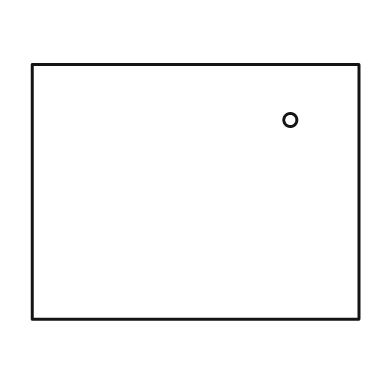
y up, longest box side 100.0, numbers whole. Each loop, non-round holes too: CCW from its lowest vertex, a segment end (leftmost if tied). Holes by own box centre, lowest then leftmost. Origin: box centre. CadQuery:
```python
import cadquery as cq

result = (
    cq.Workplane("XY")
    .moveTo(-50.0, -39.0)
    .lineTo(50.0, -39.0)
    .lineTo(50.0, 39.0)
    .lineTo(-50.0, 39.0)
    .close()
    .moveTo(29.0, 22.0)
    .circle(2.0)
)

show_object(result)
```